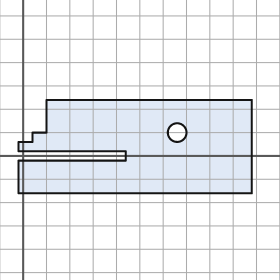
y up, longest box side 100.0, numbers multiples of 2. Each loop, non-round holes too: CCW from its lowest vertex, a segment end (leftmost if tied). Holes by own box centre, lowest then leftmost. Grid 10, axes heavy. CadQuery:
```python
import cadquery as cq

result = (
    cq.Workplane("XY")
    .moveTo(-2.0, -16.0)
    .lineTo(98.0, -16.0)
    .lineTo(98.0, 24.0)
    .lineTo(10.0, 24.0)
    .lineTo(10.0, 10.0)
    .lineTo(4.0, 10.0)
    .lineTo(4.0, 6.0)
    .lineTo(-2.0, 6.0)
    .lineTo(-2.0, 2.0)
    .lineTo(44.0, 2.0)
    .lineTo(44.0, -2.0)
    .lineTo(-2.0, -2.0)
    .close()
    .moveTo(66.0, 10.0)
    .circle(4.0)
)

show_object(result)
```